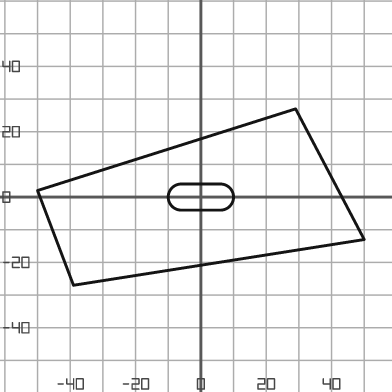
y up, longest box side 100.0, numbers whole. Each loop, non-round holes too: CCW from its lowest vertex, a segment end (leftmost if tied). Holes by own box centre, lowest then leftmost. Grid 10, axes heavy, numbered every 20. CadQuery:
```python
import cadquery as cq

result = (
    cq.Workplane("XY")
    .moveTo(-39.0, -27.0)
    .lineTo(50.0, -13.0)
    .lineTo(29.0, 27.0)
    .lineTo(-50.0, 2.0)
    .close()
    .moveTo(-6.0, -4.0)
    .lineTo(6.0, -4.0)
    .threePointArc((10.0, 0.0), (6.0, 4.0))
    .lineTo(-6.0, 4.0)
    .threePointArc((-10.0, 0.0), (-6.0, -4.0))
    .close()
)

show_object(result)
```